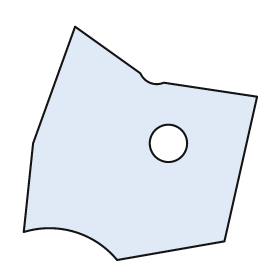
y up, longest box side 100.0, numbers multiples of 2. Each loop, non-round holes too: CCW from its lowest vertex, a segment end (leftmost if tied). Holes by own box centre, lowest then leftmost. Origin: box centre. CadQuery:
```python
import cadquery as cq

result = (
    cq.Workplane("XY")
    .moveTo(-10.0, -50.0)
    .lineTo(36.0, -42.0)
    .lineTo(50.0, 20.0)
    .lineTo(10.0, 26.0)
    .threePointArc((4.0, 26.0), (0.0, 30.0))
    .lineTo(-28.0, 50.0)
    .lineTo(-46.0, 0.0)
    .lineTo(-50.0, -38.0)
    .threePointArc((-28.0, -38.0), (-10.0, -50.0))
    .close()
    .moveTo(12.0, 0.0)
    .circle(8.0)
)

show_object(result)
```